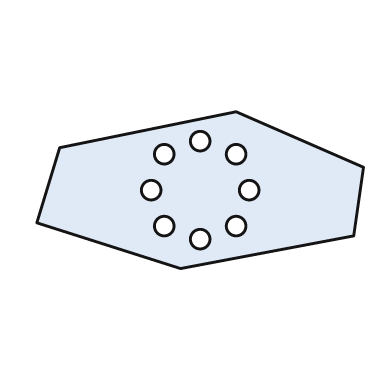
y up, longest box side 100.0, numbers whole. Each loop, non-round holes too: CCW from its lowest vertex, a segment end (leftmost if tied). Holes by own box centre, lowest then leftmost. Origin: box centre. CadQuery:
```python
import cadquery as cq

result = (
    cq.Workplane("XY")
    .moveTo(-6.0, -24.0)
    .lineTo(47.0, -14.0)
    .lineTo(50.0, 7.0)
    .lineTo(11.0, 24.0)
    .lineTo(-43.0, 13.0)
    .lineTo(-50.0, -10.0)
    .close()
    .moveTo(0.0, -15.0)
    .circle(3.0)
    .moveTo(-11.0, -11.0)
    .circle(3.0)
    .moveTo(11.0, -11.0)
    .circle(3.0)
    .moveTo(-15.0, 0.0)
    .circle(3.0)
    .moveTo(15.0, 0.0)
    .circle(3.0)
    .moveTo(-11.0, 11.0)
    .circle(3.0)
    .moveTo(11.0, 11.0)
    .circle(3.0)
    .moveTo(0.0, 15.0)
    .circle(3.0)
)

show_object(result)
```